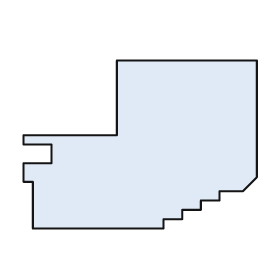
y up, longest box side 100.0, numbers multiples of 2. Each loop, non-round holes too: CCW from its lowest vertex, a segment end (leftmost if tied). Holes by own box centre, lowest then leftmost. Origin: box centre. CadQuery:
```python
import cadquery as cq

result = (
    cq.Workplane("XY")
    .moveTo(-46.0, -36.0)
    .lineTo(10.0, -36.0)
    .lineTo(10.0, -32.0)
    .lineTo(18.0, -32.0)
    .lineTo(18.0, -28.0)
    .lineTo(26.0, -28.0)
    .lineTo(26.0, -24.0)
    .lineTo(34.0, -24.0)
    .lineTo(34.0, -20.0)
    .lineTo(44.0, -20.0)
    .lineTo(50.0, -14.0)
    .lineTo(50.0, 36.0)
    .lineTo(-10.0, 36.0)
    .lineTo(-10.0, 4.0)
    .lineTo(-50.0, 4.0)
    .lineTo(-50.0, 0.0)
    .lineTo(-38.0, 0.0)
    .lineTo(-38.0, -8.0)
    .lineTo(-50.0, -8.0)
    .lineTo(-50.0, -16.0)
    .lineTo(-46.0, -16.0)
    .close()
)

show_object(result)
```